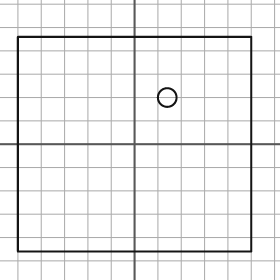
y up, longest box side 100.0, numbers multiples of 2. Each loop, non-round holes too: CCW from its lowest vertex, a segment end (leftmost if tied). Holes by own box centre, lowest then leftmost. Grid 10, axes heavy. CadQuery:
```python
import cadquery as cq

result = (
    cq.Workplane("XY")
    .moveTo(-50.0, -46.0)
    .lineTo(50.0, -46.0)
    .lineTo(50.0, 46.0)
    .lineTo(-50.0, 46.0)
    .close()
    .moveTo(14.0, 20.0)
    .circle(4.0)
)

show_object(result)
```